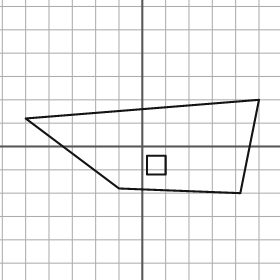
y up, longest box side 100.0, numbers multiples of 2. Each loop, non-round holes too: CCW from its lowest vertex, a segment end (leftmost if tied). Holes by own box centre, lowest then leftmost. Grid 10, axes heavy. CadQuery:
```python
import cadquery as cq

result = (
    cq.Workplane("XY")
    .moveTo(42.0, -20.0)
    .lineTo(50.0, 20.0)
    .lineTo(-50.0, 12.0)
    .lineTo(-10.0, -18.0)
    .close()
    .moveTo(2.0, -12.0)
    .lineTo(10.0, -12.0)
    .lineTo(10.0, -4.0)
    .lineTo(2.0, -4.0)
    .close()
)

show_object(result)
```